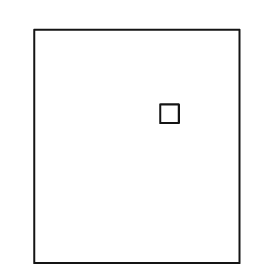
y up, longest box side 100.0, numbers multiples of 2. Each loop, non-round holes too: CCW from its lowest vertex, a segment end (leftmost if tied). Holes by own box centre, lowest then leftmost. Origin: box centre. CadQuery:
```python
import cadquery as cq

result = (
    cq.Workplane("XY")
    .moveTo(-44.0, -50.0)
    .lineTo(44.0, -50.0)
    .lineTo(44.0, 50.0)
    .lineTo(-44.0, 50.0)
    .close()
    .moveTo(10.0, 10.0)
    .lineTo(18.0, 10.0)
    .lineTo(18.0, 18.0)
    .lineTo(10.0, 18.0)
    .close()
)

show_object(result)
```